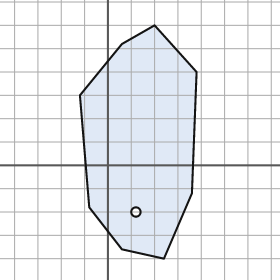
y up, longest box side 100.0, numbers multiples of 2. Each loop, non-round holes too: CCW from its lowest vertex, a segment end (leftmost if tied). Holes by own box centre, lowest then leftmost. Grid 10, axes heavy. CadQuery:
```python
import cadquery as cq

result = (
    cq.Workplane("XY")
    .moveTo(24.0, -40.0)
    .lineTo(36.0, -12.0)
    .lineTo(38.0, 40.0)
    .lineTo(20.0, 60.0)
    .lineTo(6.0, 52.0)
    .lineTo(-12.0, 30.0)
    .lineTo(-8.0, -18.0)
    .lineTo(6.0, -36.0)
    .close()
    .moveTo(12.0, -20.0)
    .circle(2.0)
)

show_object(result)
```